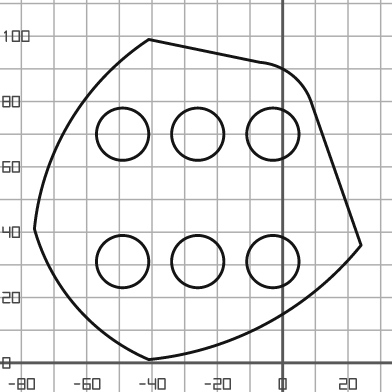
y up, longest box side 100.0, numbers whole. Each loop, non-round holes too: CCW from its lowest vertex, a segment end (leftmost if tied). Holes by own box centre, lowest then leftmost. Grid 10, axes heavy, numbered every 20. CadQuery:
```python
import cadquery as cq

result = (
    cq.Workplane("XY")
    .moveTo(-41.0, 1.0)
    .threePointArc((-5.0, 12.0), (24.0, 36.0))
    .lineTo(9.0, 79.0)
    .threePointArc((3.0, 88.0), (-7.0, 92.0))
    .lineTo(-41.0, 99.0)
    .threePointArc((-65.0, 74.0), (-76.0, 41.0))
    .threePointArc((-63.0, 17.0), (-41.0, 1.0))
    .close()
    .moveTo(-49.0, 31.0)
    .circle(8.0)
    .moveTo(-26.0, 31.0)
    .circle(8.0)
    .moveTo(-3.0, 31.0)
    .circle(8.0)
    .moveTo(-49.0, 70.0)
    .circle(8.0)
    .moveTo(-26.0, 70.0)
    .circle(8.0)
    .moveTo(-3.0, 70.0)
    .circle(8.0)
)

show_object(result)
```